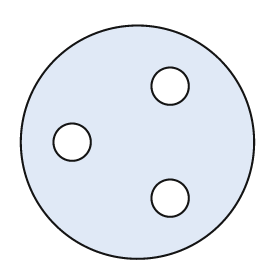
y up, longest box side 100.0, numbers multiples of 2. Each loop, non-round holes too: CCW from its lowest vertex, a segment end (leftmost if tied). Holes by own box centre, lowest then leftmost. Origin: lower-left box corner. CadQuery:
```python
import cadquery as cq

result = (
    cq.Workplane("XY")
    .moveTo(50.0, 50.0)
    .circle(50.0)
    .moveTo(64.0, 26.0)
    .circle(8.0)
    .moveTo(22.0, 50.0)
    .circle(8.0)
    .moveTo(64.0, 74.0)
    .circle(8.0)
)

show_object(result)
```